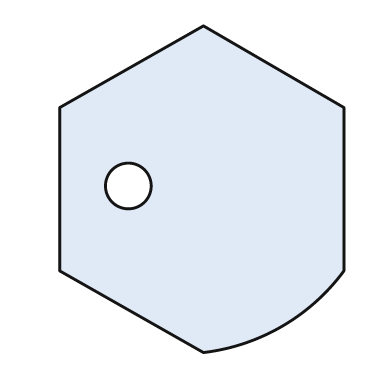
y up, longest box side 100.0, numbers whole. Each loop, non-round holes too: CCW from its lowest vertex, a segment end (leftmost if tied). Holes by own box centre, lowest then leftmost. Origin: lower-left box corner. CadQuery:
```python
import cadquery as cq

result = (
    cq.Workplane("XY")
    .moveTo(44.0, 0.0)
    .threePointArc((68.0, 8.0), (87.0, 25.0))
    .lineTo(87.0, 75.0)
    .lineTo(44.0, 100.0)
    .lineTo(0.0, 75.0)
    .lineTo(0.0, 25.0)
    .close()
    .moveTo(21.0, 51.0)
    .circle(7.0)
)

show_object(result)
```